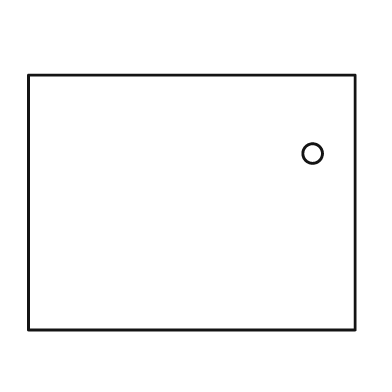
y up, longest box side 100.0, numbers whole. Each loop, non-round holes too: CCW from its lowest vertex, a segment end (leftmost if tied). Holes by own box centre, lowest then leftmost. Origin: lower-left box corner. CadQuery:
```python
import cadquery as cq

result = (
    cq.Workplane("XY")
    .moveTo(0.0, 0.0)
    .lineTo(100.0, 0.0)
    .lineTo(100.0, 78.0)
    .lineTo(0.0, 78.0)
    .close()
    .moveTo(87.0, 54.0)
    .circle(3.0)
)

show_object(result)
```